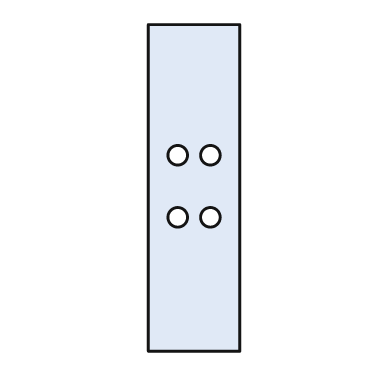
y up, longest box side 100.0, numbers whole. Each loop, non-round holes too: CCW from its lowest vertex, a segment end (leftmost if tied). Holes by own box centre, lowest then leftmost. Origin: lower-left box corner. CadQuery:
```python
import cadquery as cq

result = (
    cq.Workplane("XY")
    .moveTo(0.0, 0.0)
    .lineTo(28.0, 0.0)
    .lineTo(28.0, 100.0)
    .lineTo(0.0, 100.0)
    .close()
    .moveTo(9.0, 41.0)
    .circle(3.0)
    .moveTo(19.0, 41.0)
    .circle(3.0)
    .moveTo(9.0, 60.0)
    .circle(3.0)
    .moveTo(19.0, 60.0)
    .circle(3.0)
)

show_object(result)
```